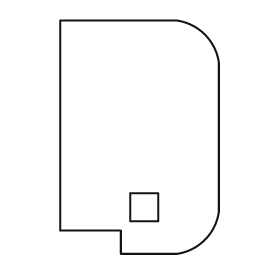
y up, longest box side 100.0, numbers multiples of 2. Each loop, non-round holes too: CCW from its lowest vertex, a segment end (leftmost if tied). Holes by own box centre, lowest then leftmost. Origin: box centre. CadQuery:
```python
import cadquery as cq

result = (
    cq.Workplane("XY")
    .moveTo(-8.0, -50.0)
    .lineTo(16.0, -50.0)
    .threePointArc((28.0, -44.0), (34.0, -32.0))
    .lineTo(34.0, 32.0)
    .threePointArc((28.0, 44.0), (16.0, 50.0))
    .lineTo(-34.0, 50.0)
    .lineTo(-34.0, -40.0)
    .lineTo(-8.0, -40.0)
    .close()
    .moveTo(-4.0, -36.0)
    .lineTo(8.0, -36.0)
    .lineTo(8.0, -24.0)
    .lineTo(-4.0, -24.0)
    .close()
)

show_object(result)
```